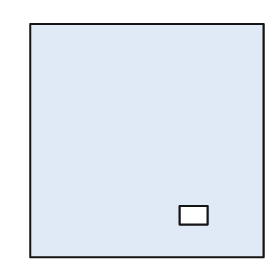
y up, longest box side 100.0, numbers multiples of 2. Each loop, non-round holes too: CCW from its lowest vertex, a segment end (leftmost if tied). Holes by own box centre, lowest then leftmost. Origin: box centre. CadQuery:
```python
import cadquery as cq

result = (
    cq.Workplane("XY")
    .moveTo(-50.0, -50.0)
    .lineTo(50.0, -50.0)
    .lineTo(50.0, 50.0)
    .lineTo(-50.0, 50.0)
    .close()
    .moveTo(14.0, -36.0)
    .lineTo(26.0, -36.0)
    .lineTo(26.0, -28.0)
    .lineTo(14.0, -28.0)
    .close()
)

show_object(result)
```